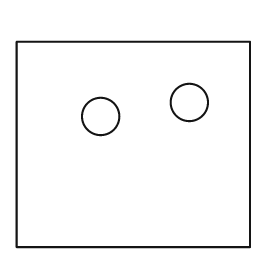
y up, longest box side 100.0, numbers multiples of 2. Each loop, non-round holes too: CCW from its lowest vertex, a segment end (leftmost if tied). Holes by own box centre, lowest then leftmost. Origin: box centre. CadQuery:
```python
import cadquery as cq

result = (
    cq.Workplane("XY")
    .moveTo(-50.0, -44.0)
    .lineTo(50.0, -44.0)
    .lineTo(50.0, 44.0)
    .lineTo(-50.0, 44.0)
    .close()
    .moveTo(-14.0, 12.0)
    .circle(8.0)
    .moveTo(24.0, 18.0)
    .circle(8.0)
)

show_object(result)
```